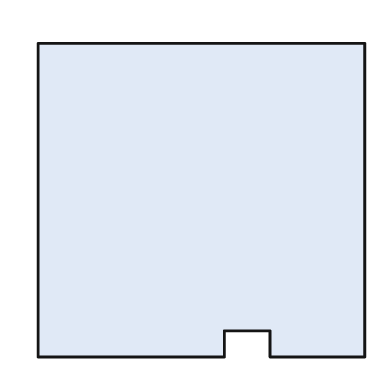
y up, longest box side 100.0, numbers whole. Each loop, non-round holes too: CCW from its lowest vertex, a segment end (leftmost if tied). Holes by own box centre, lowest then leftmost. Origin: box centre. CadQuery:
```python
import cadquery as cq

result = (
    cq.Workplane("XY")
    .moveTo(-50.0, -48.0)
    .lineTo(7.0, -48.0)
    .lineTo(7.0, -40.0)
    .lineTo(21.0, -40.0)
    .lineTo(21.0, -48.0)
    .lineTo(50.0, -48.0)
    .lineTo(50.0, 48.0)
    .lineTo(-50.0, 48.0)
    .close()
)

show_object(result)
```